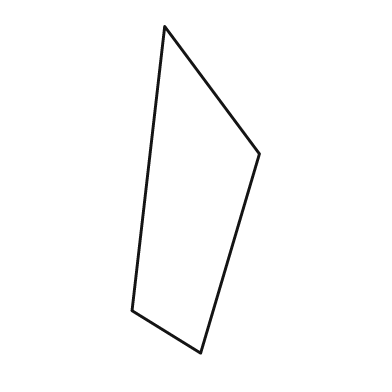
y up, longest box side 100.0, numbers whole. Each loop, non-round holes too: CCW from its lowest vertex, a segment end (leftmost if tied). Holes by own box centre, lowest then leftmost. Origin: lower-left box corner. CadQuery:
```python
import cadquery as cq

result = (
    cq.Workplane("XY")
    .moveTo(21.0, 0.0)
    .lineTo(39.0, 61.0)
    .lineTo(10.0, 100.0)
    .lineTo(0.0, 13.0)
    .close()
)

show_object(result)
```